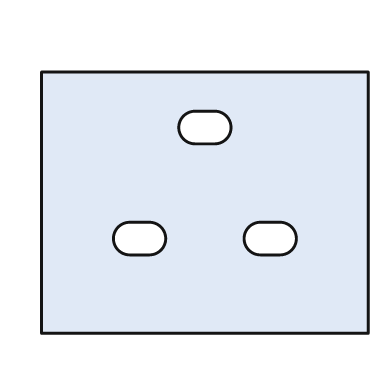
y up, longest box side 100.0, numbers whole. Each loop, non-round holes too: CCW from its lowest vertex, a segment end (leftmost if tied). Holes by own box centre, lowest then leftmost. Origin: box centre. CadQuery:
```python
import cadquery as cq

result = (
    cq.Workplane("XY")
    .moveTo(-50.0, -40.0)
    .lineTo(50.0, -40.0)
    .lineTo(50.0, 40.0)
    .lineTo(-50.0, 40.0)
    .close()
    .moveTo(-23.0, -16.0)
    .lineTo(-17.0, -16.0)
    .threePointArc((-12.0, -11.0), (-17.0, -6.0))
    .lineTo(-23.0, -6.0)
    .threePointArc((-28.0, -11.0), (-23.0, -16.0))
    .close()
    .moveTo(17.0, -16.0)
    .lineTo(23.0, -16.0)
    .threePointArc((28.0, -11.0), (23.0, -6.0))
    .lineTo(17.0, -6.0)
    .threePointArc((12.0, -11.0), (17.0, -16.0))
    .close()
    .moveTo(-3.0, 18.0)
    .lineTo(3.0, 18.0)
    .threePointArc((8.0, 23.0), (3.0, 28.0))
    .lineTo(-3.0, 28.0)
    .threePointArc((-8.0, 23.0), (-3.0, 18.0))
    .close()
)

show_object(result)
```